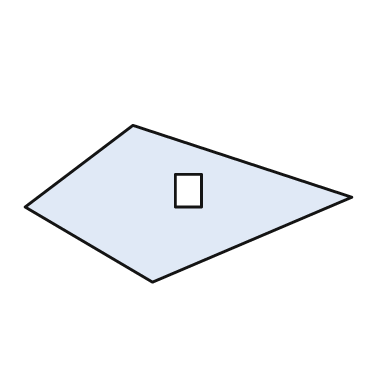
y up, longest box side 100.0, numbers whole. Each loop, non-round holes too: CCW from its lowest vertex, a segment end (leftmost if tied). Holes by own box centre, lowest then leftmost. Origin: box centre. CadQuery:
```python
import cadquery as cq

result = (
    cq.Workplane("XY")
    .moveTo(-11.0, -24.0)
    .lineTo(50.0, 2.0)
    .lineTo(-17.0, 24.0)
    .lineTo(-50.0, -1.0)
    .close()
    .moveTo(-4.0, -1.0)
    .lineTo(4.0, -1.0)
    .lineTo(4.0, 9.0)
    .lineTo(-4.0, 9.0)
    .close()
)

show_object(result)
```